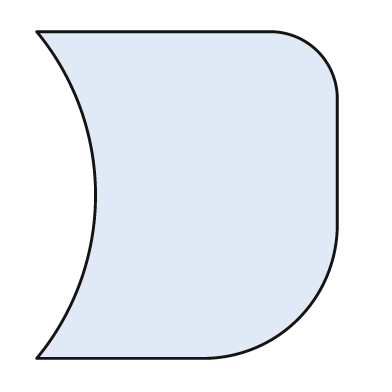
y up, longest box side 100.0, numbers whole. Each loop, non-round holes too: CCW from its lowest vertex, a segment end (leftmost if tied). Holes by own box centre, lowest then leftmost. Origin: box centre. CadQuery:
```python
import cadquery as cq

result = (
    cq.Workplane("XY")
    .moveTo(-46.0, -50.0)
    .lineTo(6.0, -50.0)
    .threePointArc((34.0, -38.0), (46.0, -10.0))
    .lineTo(46.0, 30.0)
    .threePointArc((40.0, 44.0), (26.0, 50.0))
    .lineTo(-46.0, 50.0)
    .threePointArc((-28.0, 0.0), (-46.0, -50.0))
    .close()
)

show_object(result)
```